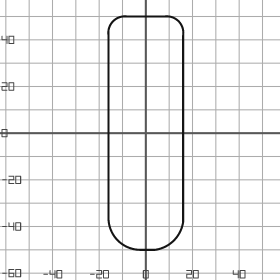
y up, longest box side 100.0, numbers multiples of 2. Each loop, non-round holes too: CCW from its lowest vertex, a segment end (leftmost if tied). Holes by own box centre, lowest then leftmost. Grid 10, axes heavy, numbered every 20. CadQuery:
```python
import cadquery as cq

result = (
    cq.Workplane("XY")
    .moveTo(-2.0, -50.0)
    .lineTo(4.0, -50.0)
    .threePointArc((12.0, -46.0), (16.0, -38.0))
    .lineTo(16.0, 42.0)
    .threePointArc((14.0, 48.0), (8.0, 50.0))
    .lineTo(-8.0, 50.0)
    .threePointArc((-14.0, 48.0), (-16.0, 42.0))
    .lineTo(-16.0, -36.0)
    .threePointArc((-12.0, -46.0), (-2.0, -50.0))
    .close()
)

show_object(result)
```